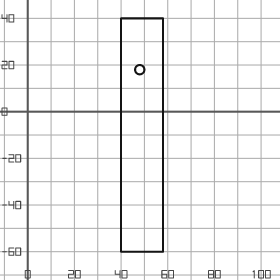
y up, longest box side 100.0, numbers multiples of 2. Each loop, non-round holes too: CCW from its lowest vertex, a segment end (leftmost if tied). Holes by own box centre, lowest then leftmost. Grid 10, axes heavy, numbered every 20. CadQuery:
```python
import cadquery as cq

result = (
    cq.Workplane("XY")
    .moveTo(40.0, -60.0)
    .lineTo(58.0, -60.0)
    .lineTo(58.0, 40.0)
    .lineTo(40.0, 40.0)
    .close()
    .moveTo(48.0, 18.0)
    .circle(2.0)
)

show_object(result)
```